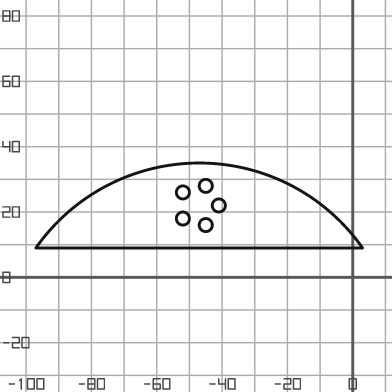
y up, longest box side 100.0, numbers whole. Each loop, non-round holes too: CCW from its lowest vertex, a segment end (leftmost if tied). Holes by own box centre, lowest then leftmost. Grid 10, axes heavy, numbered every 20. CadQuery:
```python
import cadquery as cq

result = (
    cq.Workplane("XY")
    .moveTo(-97.0, 9.0)
    .lineTo(3.0, 9.0)
    .threePointArc((-47.0, 35.0), (-97.0, 9.0))
    .close()
    .moveTo(-45.0, 16.0)
    .circle(2.0)
    .moveTo(-52.0, 18.0)
    .circle(2.0)
    .moveTo(-41.0, 22.0)
    .circle(2.0)
    .moveTo(-52.0, 26.0)
    .circle(2.0)
    .moveTo(-45.0, 28.0)
    .circle(2.0)
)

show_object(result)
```